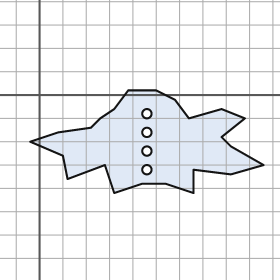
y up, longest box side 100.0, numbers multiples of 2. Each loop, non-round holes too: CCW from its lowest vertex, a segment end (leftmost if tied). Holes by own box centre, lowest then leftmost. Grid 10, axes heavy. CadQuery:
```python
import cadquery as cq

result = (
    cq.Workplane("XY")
    .moveTo(32.0, -42.0)
    .lineTo(44.0, -38.0)
    .lineTo(54.0, -38.0)
    .lineTo(66.0, -42.0)
    .lineTo(66.0, -32.0)
    .lineTo(82.0, -34.0)
    .lineTo(96.0, -30.0)
    .lineTo(82.0, -22.0)
    .lineTo(78.0, -18.0)
    .lineTo(88.0, -10.0)
    .lineTo(78.0, -6.0)
    .lineTo(64.0, -10.0)
    .lineTo(58.0, -2.0)
    .lineTo(50.0, 2.0)
    .lineTo(38.0, 2.0)
    .lineTo(32.0, -6.0)
    .lineTo(26.0, -10.0)
    .lineTo(22.0, -14.0)
    .lineTo(8.0, -16.0)
    .lineTo(-4.0, -20.0)
    .lineTo(10.0, -26.0)
    .lineTo(12.0, -36.0)
    .lineTo(28.0, -30.0)
    .close()
    .moveTo(46.0, -32.0)
    .circle(2.0)
    .moveTo(46.0, -24.0)
    .circle(2.0)
    .moveTo(46.0, -16.0)
    .circle(2.0)
    .moveTo(46.0, -8.0)
    .circle(2.0)
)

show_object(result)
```